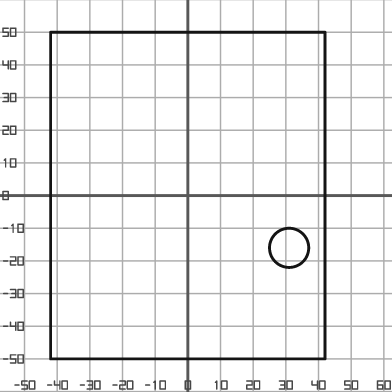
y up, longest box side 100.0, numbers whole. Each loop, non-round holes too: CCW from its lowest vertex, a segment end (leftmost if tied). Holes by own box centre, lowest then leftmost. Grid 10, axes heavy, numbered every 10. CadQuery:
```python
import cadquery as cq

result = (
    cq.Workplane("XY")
    .moveTo(-42.0, -50.0)
    .lineTo(42.0, -50.0)
    .lineTo(42.0, 50.0)
    .lineTo(-42.0, 50.0)
    .close()
    .moveTo(31.0, -16.0)
    .circle(6.0)
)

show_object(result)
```